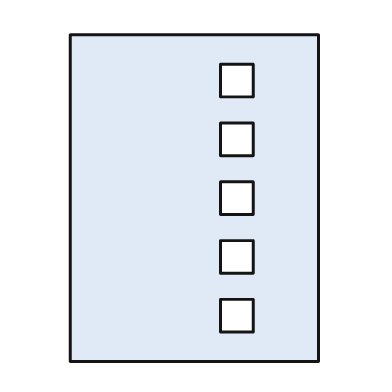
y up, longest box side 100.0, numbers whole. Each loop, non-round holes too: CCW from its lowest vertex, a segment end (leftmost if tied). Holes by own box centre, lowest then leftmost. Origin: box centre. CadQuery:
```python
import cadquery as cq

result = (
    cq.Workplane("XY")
    .moveTo(-38.0, -50.0)
    .lineTo(38.0, -50.0)
    .lineTo(38.0, 50.0)
    .lineTo(-38.0, 50.0)
    .close()
    .moveTo(8.0, -41.0)
    .lineTo(18.0, -41.0)
    .lineTo(18.0, -31.0)
    .lineTo(8.0, -31.0)
    .close()
    .moveTo(8.0, -23.0)
    .lineTo(18.0, -23.0)
    .lineTo(18.0, -13.0)
    .lineTo(8.0, -13.0)
    .close()
    .moveTo(8.0, -5.0)
    .lineTo(18.0, -5.0)
    .lineTo(18.0, 5.0)
    .lineTo(8.0, 5.0)
    .close()
    .moveTo(8.0, 13.0)
    .lineTo(18.0, 13.0)
    .lineTo(18.0, 23.0)
    .lineTo(8.0, 23.0)
    .close()
    .moveTo(8.0, 31.0)
    .lineTo(18.0, 31.0)
    .lineTo(18.0, 41.0)
    .lineTo(8.0, 41.0)
    .close()
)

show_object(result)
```